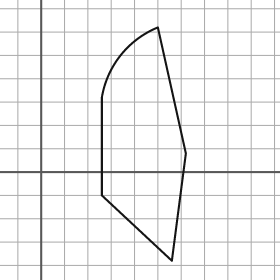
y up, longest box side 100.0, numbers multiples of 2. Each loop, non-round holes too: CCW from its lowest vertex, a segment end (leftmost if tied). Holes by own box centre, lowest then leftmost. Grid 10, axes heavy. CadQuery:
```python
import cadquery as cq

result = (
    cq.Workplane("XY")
    .moveTo(56.0, -38.0)
    .lineTo(62.0, 8.0)
    .lineTo(50.0, 62.0)
    .threePointArc((34.0, 50.0), (26.0, 32.0))
    .lineTo(26.0, -10.0)
    .close()
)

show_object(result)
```